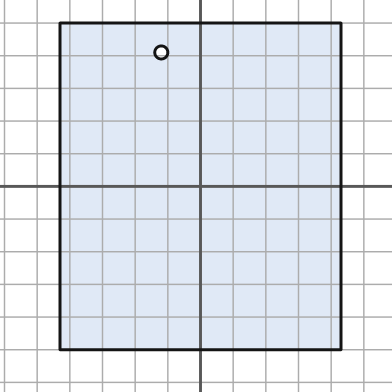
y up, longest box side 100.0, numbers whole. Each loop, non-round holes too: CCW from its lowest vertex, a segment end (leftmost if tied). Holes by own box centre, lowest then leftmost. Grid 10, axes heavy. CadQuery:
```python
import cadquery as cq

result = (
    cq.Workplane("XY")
    .moveTo(-43.0, -50.0)
    .lineTo(43.0, -50.0)
    .lineTo(43.0, 50.0)
    .lineTo(-43.0, 50.0)
    .close()
    .moveTo(-12.0, 41.0)
    .circle(2.0)
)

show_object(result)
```